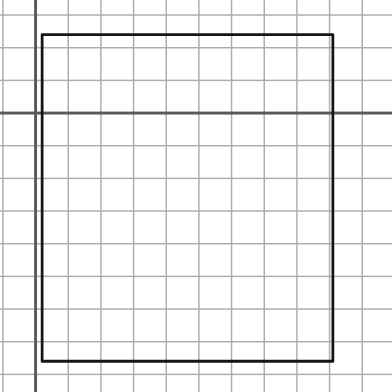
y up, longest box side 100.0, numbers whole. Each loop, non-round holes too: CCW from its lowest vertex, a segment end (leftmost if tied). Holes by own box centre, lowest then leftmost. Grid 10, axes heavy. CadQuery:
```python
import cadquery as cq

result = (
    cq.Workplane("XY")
    .moveTo(2.0, -76.0)
    .lineTo(91.0, -76.0)
    .lineTo(91.0, 24.0)
    .lineTo(2.0, 24.0)
    .close()
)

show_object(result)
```